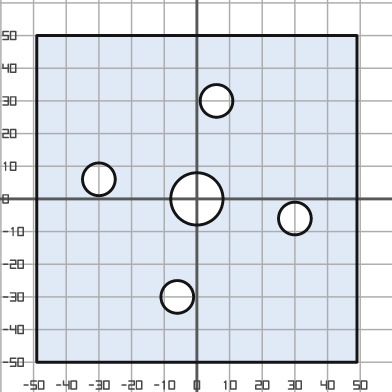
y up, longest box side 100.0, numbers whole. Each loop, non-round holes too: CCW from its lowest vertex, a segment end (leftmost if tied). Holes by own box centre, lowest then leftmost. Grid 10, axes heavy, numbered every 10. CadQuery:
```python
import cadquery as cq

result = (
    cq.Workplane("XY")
    .moveTo(-49.0, -50.0)
    .lineTo(49.0, -50.0)
    .lineTo(49.0, 50.0)
    .lineTo(-49.0, 50.0)
    .close()
    .moveTo(-6.0, -30.0)
    .circle(5.0)
    .moveTo(30.0, -6.0)
    .circle(5.0)
    .moveTo(0.0, 0.0)
    .circle(8.0)
    .moveTo(-30.0, 6.0)
    .circle(5.0)
    .moveTo(6.0, 30.0)
    .circle(5.0)
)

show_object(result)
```